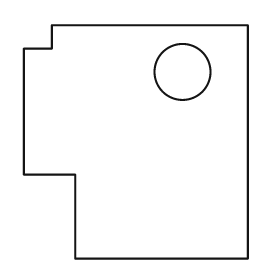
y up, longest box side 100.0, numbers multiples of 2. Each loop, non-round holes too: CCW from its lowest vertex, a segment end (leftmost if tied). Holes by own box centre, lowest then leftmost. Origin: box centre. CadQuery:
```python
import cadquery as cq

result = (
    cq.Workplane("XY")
    .moveTo(-26.0, -50.0)
    .lineTo(48.0, -50.0)
    .lineTo(48.0, 50.0)
    .lineTo(-36.0, 50.0)
    .lineTo(-36.0, 40.0)
    .lineTo(-48.0, 40.0)
    .lineTo(-48.0, -14.0)
    .lineTo(-26.0, -14.0)
    .close()
    .moveTo(20.0, 30.0)
    .circle(12.0)
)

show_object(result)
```